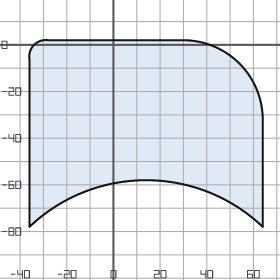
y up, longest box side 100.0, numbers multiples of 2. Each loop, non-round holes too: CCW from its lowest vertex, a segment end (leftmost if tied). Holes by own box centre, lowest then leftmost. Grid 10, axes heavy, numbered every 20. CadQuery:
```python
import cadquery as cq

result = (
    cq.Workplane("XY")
    .moveTo(-36.0, -78.0)
    .threePointArc((14.0, -58.0), (64.0, -78.0))
    .lineTo(64.0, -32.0)
    .threePointArc((54.0, -8.0), (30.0, 2.0))
    .lineTo(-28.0, 2.0)
    .threePointArc((-34.0, 0.0), (-36.0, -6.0))
    .close()
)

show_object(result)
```